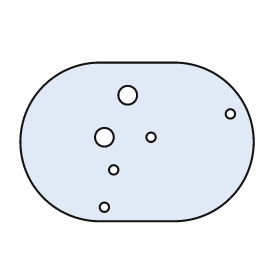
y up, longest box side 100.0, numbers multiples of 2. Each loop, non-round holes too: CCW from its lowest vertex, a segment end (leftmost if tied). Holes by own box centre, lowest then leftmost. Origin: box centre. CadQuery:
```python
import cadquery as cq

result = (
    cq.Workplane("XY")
    .moveTo(-16.0, -34.0)
    .lineTo(16.0, -34.0)
    .threePointArc((50.0, 0.0), (16.0, 34.0))
    .lineTo(-16.0, 34.0)
    .threePointArc((-50.0, 0.0), (-16.0, -34.0))
    .close()
    .moveTo(-14.0, -28.0)
    .circle(2.0)
    .moveTo(-10.0, -12.0)
    .circle(2.0)
    .moveTo(-14.0, 2.0)
    .circle(4.0)
    .moveTo(6.0, 2.0)
    .circle(2.0)
    .moveTo(40.0, 12.0)
    .circle(2.0)
    .moveTo(-4.0, 20.0)
    .circle(4.0)
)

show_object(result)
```